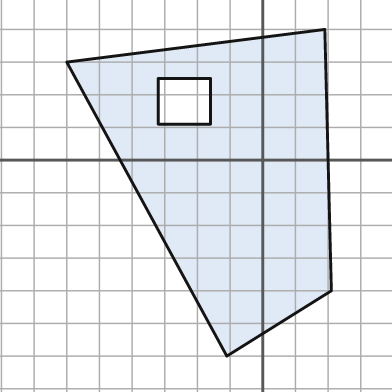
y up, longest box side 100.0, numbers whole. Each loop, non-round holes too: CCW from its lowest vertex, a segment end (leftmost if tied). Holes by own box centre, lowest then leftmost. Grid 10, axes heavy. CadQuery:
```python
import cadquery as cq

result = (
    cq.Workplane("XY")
    .moveTo(-11.0, -60.0)
    .lineTo(21.0, -40.0)
    .lineTo(19.0, 40.0)
    .lineTo(-60.0, 30.0)
    .close()
    .moveTo(-32.0, 11.0)
    .lineTo(-16.0, 11.0)
    .lineTo(-16.0, 25.0)
    .lineTo(-32.0, 25.0)
    .close()
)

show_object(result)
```